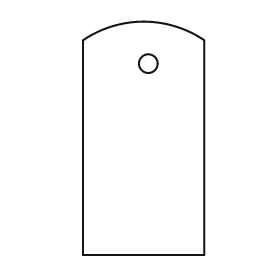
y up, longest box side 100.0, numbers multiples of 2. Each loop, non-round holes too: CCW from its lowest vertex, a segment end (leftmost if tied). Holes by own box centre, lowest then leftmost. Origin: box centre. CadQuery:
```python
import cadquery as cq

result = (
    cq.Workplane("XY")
    .moveTo(-26.0, -50.0)
    .lineTo(26.0, -50.0)
    .lineTo(26.0, 42.0)
    .threePointArc((0.0, 50.0), (-26.0, 42.0))
    .close()
    .moveTo(2.0, 32.0)
    .circle(4.0)
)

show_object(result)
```